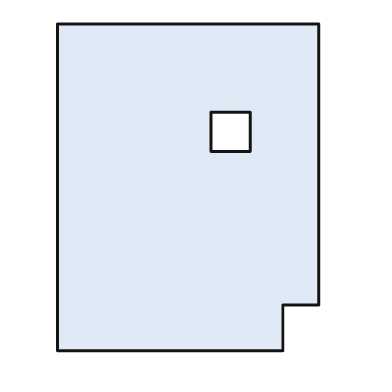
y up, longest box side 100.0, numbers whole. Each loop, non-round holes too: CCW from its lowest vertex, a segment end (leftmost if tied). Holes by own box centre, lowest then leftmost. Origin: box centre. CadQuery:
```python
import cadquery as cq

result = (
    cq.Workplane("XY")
    .moveTo(-40.0, -50.0)
    .lineTo(29.0, -50.0)
    .lineTo(29.0, -36.0)
    .lineTo(40.0, -36.0)
    .lineTo(40.0, 50.0)
    .lineTo(-40.0, 50.0)
    .close()
    .moveTo(7.0, 11.0)
    .lineTo(19.0, 11.0)
    .lineTo(19.0, 23.0)
    .lineTo(7.0, 23.0)
    .close()
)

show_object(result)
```